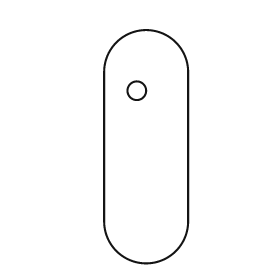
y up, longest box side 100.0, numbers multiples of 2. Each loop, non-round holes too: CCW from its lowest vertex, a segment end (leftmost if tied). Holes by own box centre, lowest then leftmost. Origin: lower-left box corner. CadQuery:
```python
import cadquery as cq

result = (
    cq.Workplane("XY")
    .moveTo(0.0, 18.0)
    .threePointArc((18.0, 0.0), (36.0, 18.0))
    .lineTo(36.0, 82.0)
    .threePointArc((18.0, 100.0), (0.0, 82.0))
    .close()
    .moveTo(14.0, 74.0)
    .circle(4.0)
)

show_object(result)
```